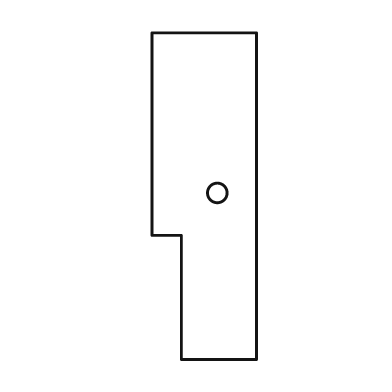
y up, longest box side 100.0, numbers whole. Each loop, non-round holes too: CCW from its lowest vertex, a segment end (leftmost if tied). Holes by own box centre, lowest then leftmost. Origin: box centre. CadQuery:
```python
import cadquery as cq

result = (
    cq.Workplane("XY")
    .moveTo(-7.0, -50.0)
    .lineTo(16.0, -50.0)
    .lineTo(16.0, 50.0)
    .lineTo(-16.0, 50.0)
    .lineTo(-16.0, -12.0)
    .lineTo(-7.0, -12.0)
    .close()
    .moveTo(4.0, 1.0)
    .circle(3.0)
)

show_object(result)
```